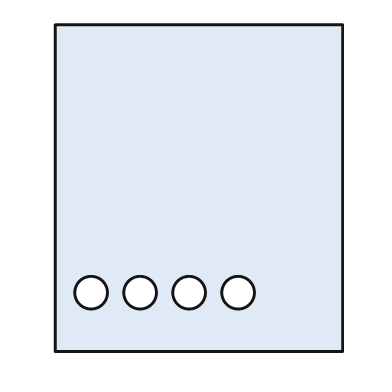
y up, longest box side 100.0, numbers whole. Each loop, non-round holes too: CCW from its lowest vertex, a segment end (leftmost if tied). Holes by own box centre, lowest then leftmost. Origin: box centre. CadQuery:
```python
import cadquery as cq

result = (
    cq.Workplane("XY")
    .moveTo(-44.0, -50.0)
    .lineTo(44.0, -50.0)
    .lineTo(44.0, 50.0)
    .lineTo(-44.0, 50.0)
    .close()
    .moveTo(-33.0, -32.0)
    .circle(5.0)
    .moveTo(-18.0, -32.0)
    .circle(5.0)
    .moveTo(-3.0, -32.0)
    .circle(5.0)
    .moveTo(12.0, -32.0)
    .circle(5.0)
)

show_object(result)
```